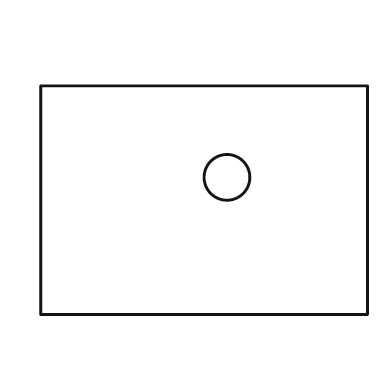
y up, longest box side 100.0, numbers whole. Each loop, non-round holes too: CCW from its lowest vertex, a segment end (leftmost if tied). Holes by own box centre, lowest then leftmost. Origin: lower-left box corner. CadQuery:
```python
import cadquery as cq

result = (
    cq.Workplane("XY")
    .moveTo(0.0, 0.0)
    .lineTo(100.0, 0.0)
    .lineTo(100.0, 70.0)
    .lineTo(0.0, 70.0)
    .close()
    .moveTo(57.0, 42.0)
    .circle(7.0)
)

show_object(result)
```